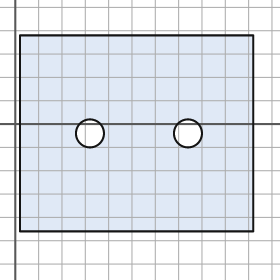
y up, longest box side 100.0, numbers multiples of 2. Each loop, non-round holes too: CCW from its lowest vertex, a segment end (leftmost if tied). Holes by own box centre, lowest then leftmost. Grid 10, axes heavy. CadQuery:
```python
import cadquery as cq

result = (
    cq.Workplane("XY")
    .moveTo(2.0, -46.0)
    .lineTo(102.0, -46.0)
    .lineTo(102.0, 38.0)
    .lineTo(2.0, 38.0)
    .close()
    .moveTo(32.0, -4.0)
    .circle(6.0)
    .moveTo(74.0, -4.0)
    .circle(6.0)
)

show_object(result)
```